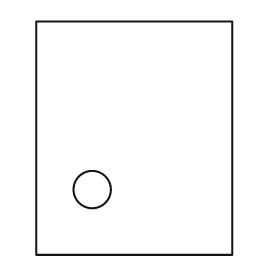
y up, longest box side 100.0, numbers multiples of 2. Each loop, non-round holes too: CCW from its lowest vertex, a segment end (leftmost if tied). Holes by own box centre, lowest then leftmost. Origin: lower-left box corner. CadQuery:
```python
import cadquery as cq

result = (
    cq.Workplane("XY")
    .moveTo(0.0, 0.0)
    .lineTo(84.0, 0.0)
    .lineTo(84.0, 100.0)
    .lineTo(0.0, 100.0)
    .close()
    .moveTo(24.0, 28.0)
    .circle(8.0)
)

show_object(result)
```